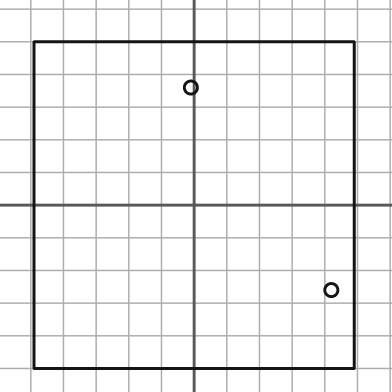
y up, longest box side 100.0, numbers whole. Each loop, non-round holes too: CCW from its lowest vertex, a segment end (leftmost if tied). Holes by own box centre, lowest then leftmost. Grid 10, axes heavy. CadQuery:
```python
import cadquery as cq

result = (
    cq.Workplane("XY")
    .moveTo(-49.0, -50.0)
    .lineTo(49.0, -50.0)
    .lineTo(49.0, 50.0)
    .lineTo(-49.0, 50.0)
    .close()
    .moveTo(42.0, -26.0)
    .circle(2.0)
    .moveTo(-1.0, 36.0)
    .circle(2.0)
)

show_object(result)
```